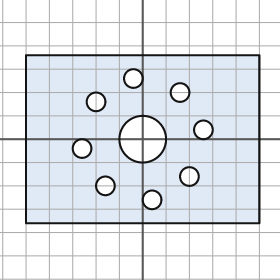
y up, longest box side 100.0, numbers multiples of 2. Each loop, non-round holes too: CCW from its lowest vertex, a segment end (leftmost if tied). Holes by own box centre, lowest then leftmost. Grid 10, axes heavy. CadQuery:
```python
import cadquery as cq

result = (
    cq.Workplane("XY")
    .moveTo(-50.0, -36.0)
    .lineTo(50.0, -36.0)
    .lineTo(50.0, 36.0)
    .lineTo(-50.0, 36.0)
    .close()
    .moveTo(4.0, -26.0)
    .circle(4.0)
    .moveTo(-16.0, -20.0)
    .circle(4.0)
    .moveTo(20.0, -16.0)
    .circle(4.0)
    .moveTo(-26.0, -4.0)
    .circle(4.0)
    .moveTo(0.0, 0.0)
    .circle(10.0)
    .moveTo(26.0, 4.0)
    .circle(4.0)
    .moveTo(-20.0, 16.0)
    .circle(4.0)
    .moveTo(16.0, 20.0)
    .circle(4.0)
    .moveTo(-4.0, 26.0)
    .circle(4.0)
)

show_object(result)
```